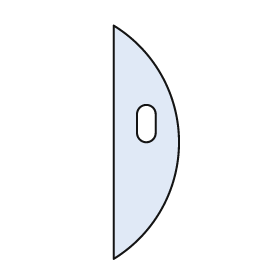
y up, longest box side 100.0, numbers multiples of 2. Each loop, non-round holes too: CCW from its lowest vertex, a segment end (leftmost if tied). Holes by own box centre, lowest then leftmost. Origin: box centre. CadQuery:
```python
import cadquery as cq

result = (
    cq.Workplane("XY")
    .moveTo(-14.0, -50.0)
    .threePointArc((14.0, 0.0), (-14.0, 50.0))
    .close()
    .moveTo(-4.0, 4.0)
    .threePointArc((0.0, 0.0), (4.0, 4.0))
    .lineTo(4.0, 12.0)
    .threePointArc((0.0, 16.0), (-4.0, 12.0))
    .close()
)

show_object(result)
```